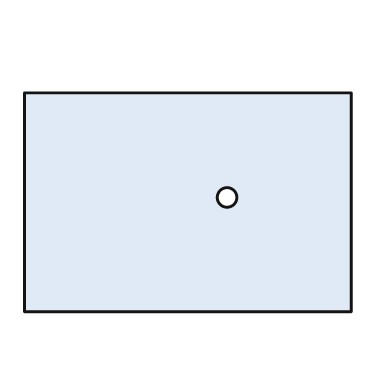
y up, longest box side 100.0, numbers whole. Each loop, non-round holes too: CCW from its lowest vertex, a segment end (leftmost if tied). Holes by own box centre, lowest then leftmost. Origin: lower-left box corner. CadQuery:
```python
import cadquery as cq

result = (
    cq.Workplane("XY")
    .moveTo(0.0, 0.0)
    .lineTo(100.0, 0.0)
    .lineTo(100.0, 67.0)
    .lineTo(0.0, 67.0)
    .close()
    .moveTo(62.0, 35.0)
    .circle(3.0)
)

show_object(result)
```